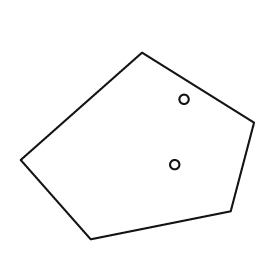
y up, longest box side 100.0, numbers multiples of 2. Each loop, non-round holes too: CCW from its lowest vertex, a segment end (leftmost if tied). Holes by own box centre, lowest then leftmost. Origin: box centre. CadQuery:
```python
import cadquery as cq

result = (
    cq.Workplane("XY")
    .moveTo(-20.0, -40.0)
    .lineTo(40.0, -28.0)
    .lineTo(50.0, 10.0)
    .lineTo(2.0, 40.0)
    .lineTo(-50.0, -6.0)
    .close()
    .moveTo(16.0, -8.0)
    .circle(2.0)
    .moveTo(20.0, 20.0)
    .circle(2.0)
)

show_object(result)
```